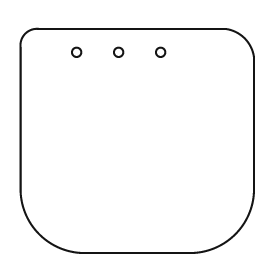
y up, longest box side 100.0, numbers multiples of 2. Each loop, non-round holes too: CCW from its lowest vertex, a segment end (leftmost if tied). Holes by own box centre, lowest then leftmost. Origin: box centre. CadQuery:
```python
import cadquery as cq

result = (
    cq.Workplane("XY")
    .moveTo(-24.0, -48.0)
    .lineTo(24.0, -48.0)
    .threePointArc((42.0, -40.0), (50.0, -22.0))
    .lineTo(50.0, 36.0)
    .threePointArc((46.0, 44.0), (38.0, 48.0))
    .lineTo(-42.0, 48.0)
    .threePointArc((-48.0, 46.0), (-50.0, 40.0))
    .lineTo(-50.0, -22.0)
    .threePointArc((-42.0, -40.0), (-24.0, -48.0))
    .close()
    .moveTo(-26.0, 38.0)
    .circle(2.0)
    .moveTo(-8.0, 38.0)
    .circle(2.0)
    .moveTo(10.0, 38.0)
    .circle(2.0)
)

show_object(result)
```